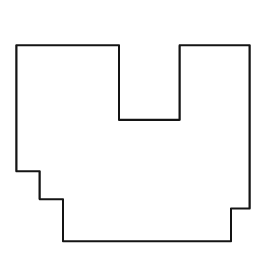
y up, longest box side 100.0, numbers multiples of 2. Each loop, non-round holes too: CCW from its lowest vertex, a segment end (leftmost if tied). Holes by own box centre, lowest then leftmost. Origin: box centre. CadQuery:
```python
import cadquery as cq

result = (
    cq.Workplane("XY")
    .moveTo(-30.0, -42.0)
    .lineTo(42.0, -42.0)
    .lineTo(42.0, -28.0)
    .lineTo(50.0, -28.0)
    .lineTo(50.0, 42.0)
    .lineTo(20.0, 42.0)
    .lineTo(20.0, 10.0)
    .lineTo(-6.0, 10.0)
    .lineTo(-6.0, 42.0)
    .lineTo(-50.0, 42.0)
    .lineTo(-50.0, -12.0)
    .lineTo(-40.0, -12.0)
    .lineTo(-40.0, -24.0)
    .lineTo(-30.0, -24.0)
    .close()
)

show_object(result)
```